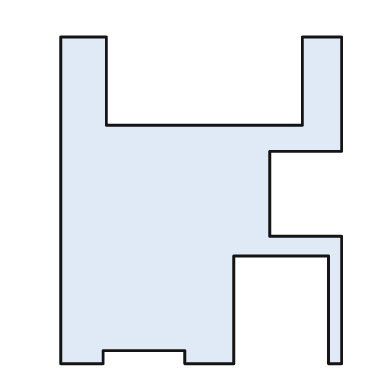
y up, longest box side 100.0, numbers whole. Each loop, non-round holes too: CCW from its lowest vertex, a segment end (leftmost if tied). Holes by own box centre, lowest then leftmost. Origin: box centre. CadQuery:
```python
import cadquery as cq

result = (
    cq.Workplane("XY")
    .moveTo(-43.0, -50.0)
    .lineTo(-30.0, -50.0)
    .lineTo(-30.0, -46.0)
    .lineTo(-5.0, -46.0)
    .lineTo(-5.0, -50.0)
    .lineTo(10.0, -50.0)
    .lineTo(10.0, -17.0)
    .lineTo(39.0, -17.0)
    .lineTo(39.0, -50.0)
    .lineTo(43.0, -50.0)
    .lineTo(43.0, -11.0)
    .lineTo(21.0, -11.0)
    .lineTo(21.0, 15.0)
    .lineTo(43.0, 15.0)
    .lineTo(43.0, 50.0)
    .lineTo(31.0, 50.0)
    .lineTo(31.0, 23.0)
    .lineTo(-29.0, 23.0)
    .lineTo(-29.0, 50.0)
    .lineTo(-43.0, 50.0)
    .close()
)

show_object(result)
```